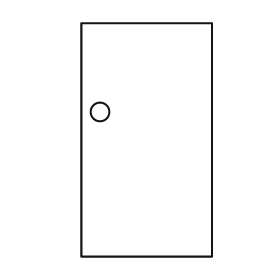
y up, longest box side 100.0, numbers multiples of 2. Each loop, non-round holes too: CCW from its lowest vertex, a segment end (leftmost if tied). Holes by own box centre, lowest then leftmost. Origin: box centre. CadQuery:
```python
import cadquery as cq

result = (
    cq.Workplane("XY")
    .moveTo(-28.0, -50.0)
    .lineTo(28.0, -50.0)
    .lineTo(28.0, 50.0)
    .lineTo(-28.0, 50.0)
    .close()
    .moveTo(-20.0, 12.0)
    .circle(4.0)
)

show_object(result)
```